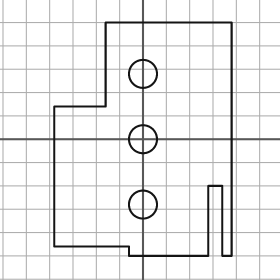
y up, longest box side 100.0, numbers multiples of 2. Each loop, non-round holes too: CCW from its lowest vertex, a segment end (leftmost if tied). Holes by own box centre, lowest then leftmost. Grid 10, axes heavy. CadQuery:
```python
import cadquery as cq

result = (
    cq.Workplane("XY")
    .moveTo(-6.0, -50.0)
    .lineTo(28.0, -50.0)
    .lineTo(28.0, -20.0)
    .lineTo(34.0, -20.0)
    .lineTo(34.0, -50.0)
    .lineTo(38.0, -50.0)
    .lineTo(38.0, 50.0)
    .lineTo(-16.0, 50.0)
    .lineTo(-16.0, 14.0)
    .lineTo(-38.0, 14.0)
    .lineTo(-38.0, -46.0)
    .lineTo(-6.0, -46.0)
    .close()
    .moveTo(0.0, -28.0)
    .circle(6.0)
    .moveTo(0.0, 0.0)
    .circle(6.0)
    .moveTo(0.0, 28.0)
    .circle(6.0)
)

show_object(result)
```